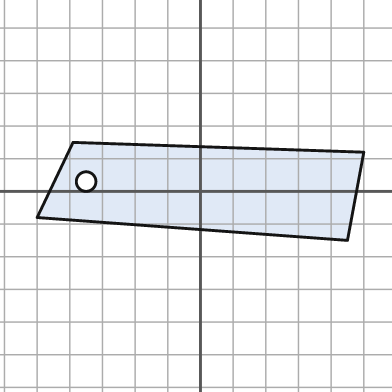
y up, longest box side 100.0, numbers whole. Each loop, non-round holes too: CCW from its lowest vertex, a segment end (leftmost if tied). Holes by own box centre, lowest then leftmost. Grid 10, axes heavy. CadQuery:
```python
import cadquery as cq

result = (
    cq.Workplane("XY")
    .moveTo(45.0, -15.0)
    .lineTo(50.0, 12.0)
    .lineTo(-39.0, 15.0)
    .lineTo(-50.0, -8.0)
    .close()
    .moveTo(-35.0, 3.0)
    .circle(3.0)
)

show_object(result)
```